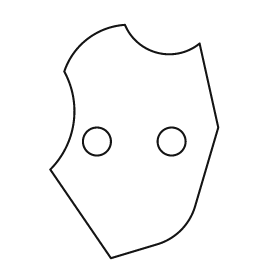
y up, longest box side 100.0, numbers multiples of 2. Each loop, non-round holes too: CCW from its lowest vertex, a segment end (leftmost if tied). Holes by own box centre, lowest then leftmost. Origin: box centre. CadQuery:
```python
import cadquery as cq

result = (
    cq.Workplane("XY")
    .moveTo(-10.0, -50.0)
    .lineTo(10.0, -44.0)
    .threePointArc((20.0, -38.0), (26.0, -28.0))
    .lineTo(36.0, 6.0)
    .lineTo(28.0, 42.0)
    .threePointArc((10.0, 38.0), (-4.0, 50.0))
    .threePointArc((-20.0, 44.0), (-30.0, 30.0))
    .threePointArc((-26.0, 8.0), (-36.0, -12.0))
    .close()
    .moveTo(-16.0, 0.0)
    .circle(6.0)
    .moveTo(16.0, 0.0)
    .circle(6.0)
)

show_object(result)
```